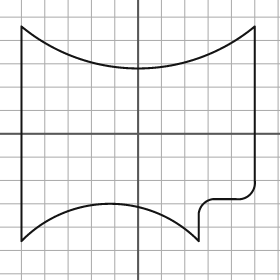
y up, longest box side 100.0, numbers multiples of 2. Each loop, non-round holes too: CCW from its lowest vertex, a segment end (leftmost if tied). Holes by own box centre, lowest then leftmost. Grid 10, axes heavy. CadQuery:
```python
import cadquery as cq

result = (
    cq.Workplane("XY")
    .moveTo(-50.0, -46.0)
    .threePointArc((-12.0, -30.0), (26.0, -46.0))
    .lineTo(26.0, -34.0)
    .threePointArc((28.0, -30.0), (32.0, -28.0))
    .lineTo(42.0, -28.0)
    .threePointArc((48.0, -26.0), (50.0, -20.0))
    .lineTo(50.0, 46.0)
    .threePointArc((0.0, 28.0), (-50.0, 46.0))
    .close()
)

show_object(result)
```